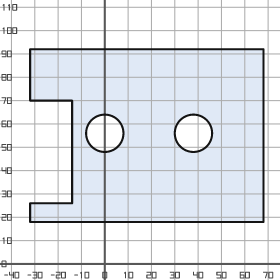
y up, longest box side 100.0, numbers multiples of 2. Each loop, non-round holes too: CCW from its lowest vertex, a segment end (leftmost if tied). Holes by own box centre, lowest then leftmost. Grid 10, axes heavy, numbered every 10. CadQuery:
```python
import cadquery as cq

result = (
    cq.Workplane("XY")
    .moveTo(-32.0, 18.0)
    .lineTo(68.0, 18.0)
    .lineTo(68.0, 92.0)
    .lineTo(-32.0, 92.0)
    .lineTo(-32.0, 70.0)
    .lineTo(-14.0, 70.0)
    .lineTo(-14.0, 26.0)
    .lineTo(-32.0, 26.0)
    .close()
    .moveTo(0.0, 56.0)
    .circle(8.0)
    .moveTo(38.0, 56.0)
    .circle(8.0)
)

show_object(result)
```